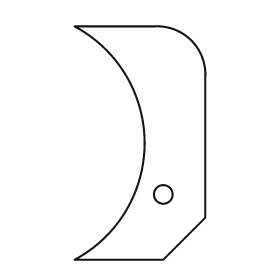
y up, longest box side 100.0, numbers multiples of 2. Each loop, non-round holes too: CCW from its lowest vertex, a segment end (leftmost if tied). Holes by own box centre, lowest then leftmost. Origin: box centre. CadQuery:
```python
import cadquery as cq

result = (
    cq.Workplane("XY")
    .moveTo(-28.0, -50.0)
    .lineTo(10.0, -50.0)
    .lineTo(28.0, -32.0)
    .lineTo(28.0, 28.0)
    .threePointArc((22.0, 44.0), (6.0, 50.0))
    .lineTo(-28.0, 50.0)
    .threePointArc((2.0, 0.0), (-28.0, -50.0))
    .close()
    .moveTo(10.0, -22.0)
    .circle(4.0)
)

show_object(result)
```